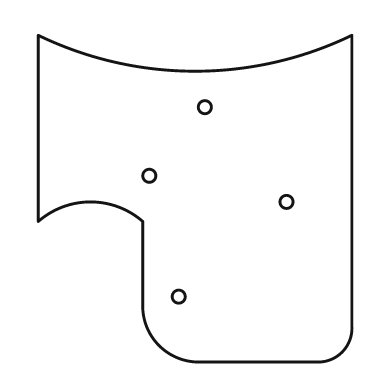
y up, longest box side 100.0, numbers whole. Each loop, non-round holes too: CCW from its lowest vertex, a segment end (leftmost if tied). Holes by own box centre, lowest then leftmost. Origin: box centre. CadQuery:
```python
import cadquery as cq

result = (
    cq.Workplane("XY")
    .moveTo(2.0, -50.0)
    .lineTo(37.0, -50.0)
    .threePointArc((45.0, -47.0), (48.0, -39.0))
    .lineTo(48.0, 50.0)
    .threePointArc((0.0, 39.0), (-48.0, 50.0))
    .lineTo(-48.0, -7.0)
    .threePointArc((-32.0, -1.0), (-16.0, -7.0))
    .lineTo(-16.0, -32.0)
    .threePointArc((-11.0, -45.0), (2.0, -50.0))
    .close()
    .moveTo(-5.0, -30.0)
    .circle(2.0)
    .moveTo(28.0, -1.0)
    .circle(2.0)
    .moveTo(-14.0, 7.0)
    .circle(2.0)
    .moveTo(3.0, 28.0)
    .circle(2.0)
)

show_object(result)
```